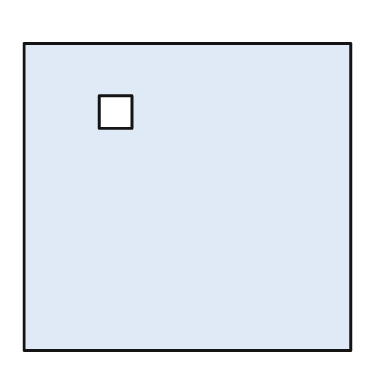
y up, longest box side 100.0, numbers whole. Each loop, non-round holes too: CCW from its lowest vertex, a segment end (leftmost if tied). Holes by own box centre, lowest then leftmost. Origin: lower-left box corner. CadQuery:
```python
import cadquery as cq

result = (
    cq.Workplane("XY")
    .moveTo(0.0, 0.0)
    .lineTo(100.0, 0.0)
    .lineTo(100.0, 94.0)
    .lineTo(0.0, 94.0)
    .close()
    .moveTo(23.0, 68.0)
    .lineTo(33.0, 68.0)
    .lineTo(33.0, 78.0)
    .lineTo(23.0, 78.0)
    .close()
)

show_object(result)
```